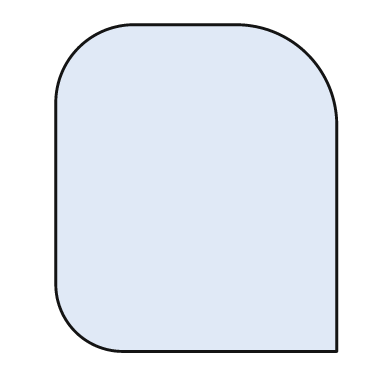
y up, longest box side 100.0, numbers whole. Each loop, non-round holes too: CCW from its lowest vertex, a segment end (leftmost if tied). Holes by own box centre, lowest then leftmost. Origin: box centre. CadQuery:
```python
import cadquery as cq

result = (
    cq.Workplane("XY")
    .moveTo(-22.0, -50.0)
    .lineTo(43.0, -50.0)
    .lineTo(43.0, 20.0)
    .threePointArc((34.0, 41.0), (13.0, 50.0))
    .lineTo(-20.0, 50.0)
    .threePointArc((-36.0, 43.0), (-43.0, 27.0))
    .lineTo(-43.0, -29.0)
    .threePointArc((-37.0, -44.0), (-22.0, -50.0))
    .close()
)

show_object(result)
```